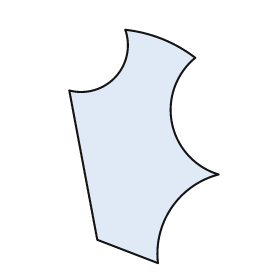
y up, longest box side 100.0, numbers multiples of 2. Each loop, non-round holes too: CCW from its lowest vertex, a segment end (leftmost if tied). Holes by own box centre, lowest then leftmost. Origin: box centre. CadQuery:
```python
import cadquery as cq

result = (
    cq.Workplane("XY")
    .moveTo(6.0, -50.0)
    .threePointArc((12.0, -26.0), (32.0, -12.0))
    .threePointArc((12.0, 10.0), (22.0, 38.0))
    .threePointArc((8.0, 46.0), (-8.0, 50.0))
    .threePointArc((-12.0, 30.0), (-32.0, 24.0))
    .lineTo(-20.0, -40.0)
    .close()
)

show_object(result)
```